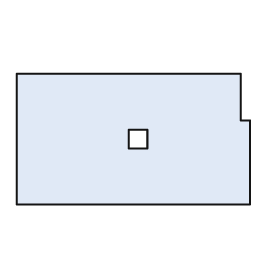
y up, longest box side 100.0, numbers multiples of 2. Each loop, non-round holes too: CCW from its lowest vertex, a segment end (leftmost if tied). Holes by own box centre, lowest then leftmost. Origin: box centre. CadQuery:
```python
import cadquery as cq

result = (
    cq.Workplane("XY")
    .moveTo(-50.0, -28.0)
    .lineTo(50.0, -28.0)
    .lineTo(50.0, 8.0)
    .lineTo(46.0, 8.0)
    .lineTo(46.0, 28.0)
    .lineTo(-50.0, 28.0)
    .close()
    .moveTo(-2.0, -4.0)
    .lineTo(6.0, -4.0)
    .lineTo(6.0, 4.0)
    .lineTo(-2.0, 4.0)
    .close()
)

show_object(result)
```